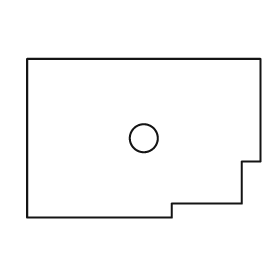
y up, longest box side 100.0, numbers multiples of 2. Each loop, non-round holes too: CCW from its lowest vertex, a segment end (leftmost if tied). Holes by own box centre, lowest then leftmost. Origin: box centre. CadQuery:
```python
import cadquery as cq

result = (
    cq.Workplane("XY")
    .moveTo(-50.0, -34.0)
    .lineTo(12.0, -34.0)
    .lineTo(12.0, -28.0)
    .lineTo(42.0, -28.0)
    .lineTo(42.0, -10.0)
    .lineTo(50.0, -10.0)
    .lineTo(50.0, 34.0)
    .lineTo(-50.0, 34.0)
    .close()
    .moveTo(0.0, 0.0)
    .circle(6.0)
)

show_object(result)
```